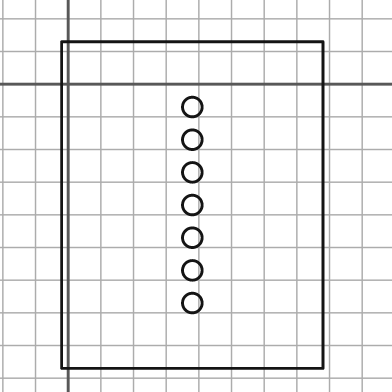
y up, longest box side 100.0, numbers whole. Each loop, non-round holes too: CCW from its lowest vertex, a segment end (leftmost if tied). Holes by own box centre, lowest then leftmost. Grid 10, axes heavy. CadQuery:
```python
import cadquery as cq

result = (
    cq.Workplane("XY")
    .moveTo(-2.0, -87.0)
    .lineTo(78.0, -87.0)
    .lineTo(78.0, 13.0)
    .lineTo(-2.0, 13.0)
    .close()
    .moveTo(38.0, -67.0)
    .circle(3.0)
    .moveTo(38.0, -57.0)
    .circle(3.0)
    .moveTo(38.0, -47.0)
    .circle(3.0)
    .moveTo(38.0, -37.0)
    .circle(3.0)
    .moveTo(38.0, -27.0)
    .circle(3.0)
    .moveTo(38.0, -17.0)
    .circle(3.0)
    .moveTo(38.0, -7.0)
    .circle(3.0)
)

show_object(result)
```